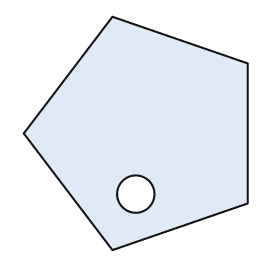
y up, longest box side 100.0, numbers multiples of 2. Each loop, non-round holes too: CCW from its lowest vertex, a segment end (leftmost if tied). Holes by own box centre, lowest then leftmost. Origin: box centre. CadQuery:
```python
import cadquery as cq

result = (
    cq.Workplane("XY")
    .moveTo(-10.0, -50.0)
    .lineTo(48.0, -30.0)
    .lineTo(48.0, 30.0)
    .lineTo(-10.0, 50.0)
    .lineTo(-48.0, 0.0)
    .close()
    .moveTo(0.0, -26.0)
    .circle(8.0)
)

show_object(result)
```